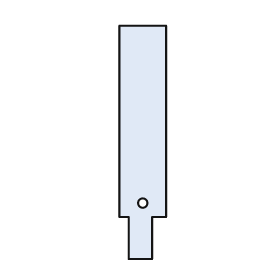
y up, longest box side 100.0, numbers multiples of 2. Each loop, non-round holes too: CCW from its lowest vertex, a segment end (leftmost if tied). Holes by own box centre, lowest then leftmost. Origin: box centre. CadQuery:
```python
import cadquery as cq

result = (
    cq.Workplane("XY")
    .moveTo(-6.0, -50.0)
    .lineTo(4.0, -50.0)
    .lineTo(4.0, -32.0)
    .lineTo(10.0, -32.0)
    .lineTo(10.0, 50.0)
    .lineTo(-10.0, 50.0)
    .lineTo(-10.0, -32.0)
    .lineTo(-6.0, -32.0)
    .close()
    .moveTo(0.0, -26.0)
    .circle(2.0)
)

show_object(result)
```